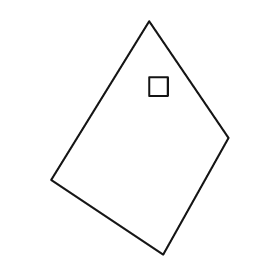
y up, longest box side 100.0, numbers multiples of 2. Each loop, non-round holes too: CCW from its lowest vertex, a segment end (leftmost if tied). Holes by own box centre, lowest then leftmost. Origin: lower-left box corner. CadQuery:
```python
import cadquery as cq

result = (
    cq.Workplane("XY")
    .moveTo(48.0, 0.0)
    .lineTo(76.0, 50.0)
    .lineTo(42.0, 100.0)
    .lineTo(0.0, 32.0)
    .close()
    .moveTo(42.0, 68.0)
    .lineTo(50.0, 68.0)
    .lineTo(50.0, 76.0)
    .lineTo(42.0, 76.0)
    .close()
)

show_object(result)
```